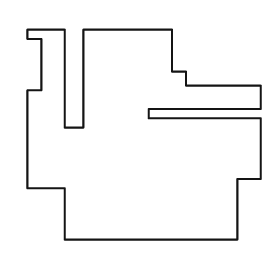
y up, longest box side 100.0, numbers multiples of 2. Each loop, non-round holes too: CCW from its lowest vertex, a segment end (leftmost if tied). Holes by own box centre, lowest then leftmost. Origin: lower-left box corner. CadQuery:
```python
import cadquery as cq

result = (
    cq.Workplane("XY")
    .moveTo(16.0, 0.0)
    .lineTo(90.0, 0.0)
    .lineTo(90.0, 26.0)
    .lineTo(100.0, 26.0)
    .lineTo(100.0, 52.0)
    .lineTo(52.0, 52.0)
    .lineTo(52.0, 56.0)
    .lineTo(100.0, 56.0)
    .lineTo(100.0, 66.0)
    .lineTo(68.0, 66.0)
    .lineTo(68.0, 72.0)
    .lineTo(62.0, 72.0)
    .lineTo(62.0, 90.0)
    .lineTo(24.0, 90.0)
    .lineTo(24.0, 48.0)
    .lineTo(16.0, 48.0)
    .lineTo(16.0, 90.0)
    .lineTo(0.0, 90.0)
    .lineTo(0.0, 86.0)
    .lineTo(6.0, 86.0)
    .lineTo(6.0, 64.0)
    .lineTo(0.0, 64.0)
    .lineTo(0.0, 22.0)
    .lineTo(16.0, 22.0)
    .close()
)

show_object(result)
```